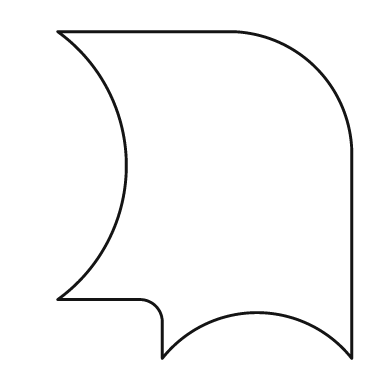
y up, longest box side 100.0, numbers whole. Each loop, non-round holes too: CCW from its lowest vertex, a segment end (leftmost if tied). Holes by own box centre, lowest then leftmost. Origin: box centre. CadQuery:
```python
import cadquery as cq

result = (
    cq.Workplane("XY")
    .moveTo(-13.0, -50.0)
    .threePointArc((16.0, -36.0), (45.0, -50.0))
    .lineTo(45.0, 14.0)
    .threePointArc((34.0, 39.0), (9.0, 50.0))
    .lineTo(-45.0, 50.0)
    .threePointArc((-24.0, 9.0), (-45.0, -32.0))
    .lineTo(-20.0, -32.0)
    .threePointArc((-15.0, -34.0), (-13.0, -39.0))
    .close()
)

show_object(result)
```